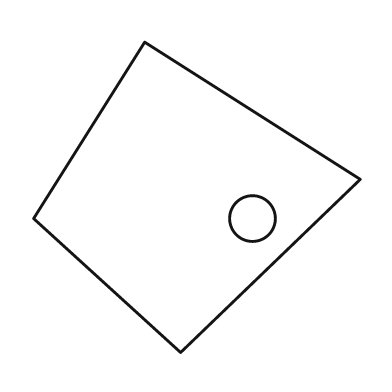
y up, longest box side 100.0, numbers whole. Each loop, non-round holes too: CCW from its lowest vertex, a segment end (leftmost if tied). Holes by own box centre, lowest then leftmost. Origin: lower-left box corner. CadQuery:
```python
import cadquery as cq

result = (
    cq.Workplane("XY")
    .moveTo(45.0, 0.0)
    .lineTo(100.0, 53.0)
    .lineTo(34.0, 95.0)
    .lineTo(0.0, 41.0)
    .close()
    .moveTo(67.0, 41.0)
    .circle(7.0)
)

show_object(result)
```